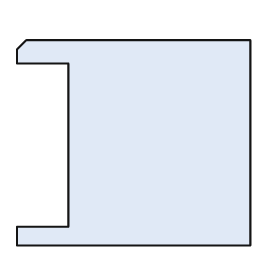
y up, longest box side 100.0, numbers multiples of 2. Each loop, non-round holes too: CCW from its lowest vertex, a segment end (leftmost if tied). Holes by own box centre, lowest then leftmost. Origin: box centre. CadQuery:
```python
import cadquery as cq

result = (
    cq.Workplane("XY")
    .moveTo(-50.0, -44.0)
    .lineTo(50.0, -44.0)
    .lineTo(50.0, 44.0)
    .lineTo(-46.0, 44.0)
    .lineTo(-50.0, 40.0)
    .lineTo(-50.0, 34.0)
    .lineTo(-28.0, 34.0)
    .lineTo(-28.0, -36.0)
    .lineTo(-50.0, -36.0)
    .close()
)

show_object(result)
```